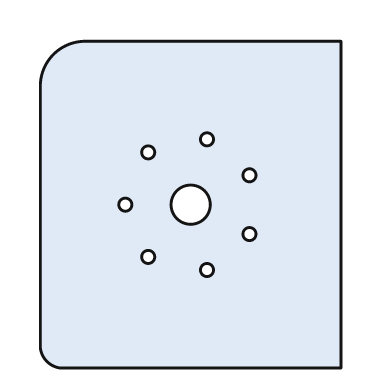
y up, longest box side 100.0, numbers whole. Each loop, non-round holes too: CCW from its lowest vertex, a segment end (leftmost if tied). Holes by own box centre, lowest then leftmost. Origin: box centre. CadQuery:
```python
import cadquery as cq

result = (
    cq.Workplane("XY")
    .moveTo(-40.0, -50.0)
    .lineTo(46.0, -50.0)
    .lineTo(46.0, 50.0)
    .lineTo(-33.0, 50.0)
    .threePointArc((-42.0, 46.0), (-46.0, 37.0))
    .lineTo(-46.0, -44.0)
    .threePointArc((-44.0, -48.0), (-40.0, -50.0))
    .close()
    .moveTo(5.0, -20.0)
    .circle(2.0)
    .moveTo(-13.0, -16.0)
    .circle(2.0)
    .moveTo(18.0, -9.0)
    .circle(2.0)
    .moveTo(-20.0, 0.0)
    .circle(2.0)
    .moveTo(0.0, 0.0)
    .circle(6.0)
    .moveTo(18.0, 9.0)
    .circle(2.0)
    .moveTo(-13.0, 16.0)
    .circle(2.0)
    .moveTo(5.0, 20.0)
    .circle(2.0)
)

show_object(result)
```